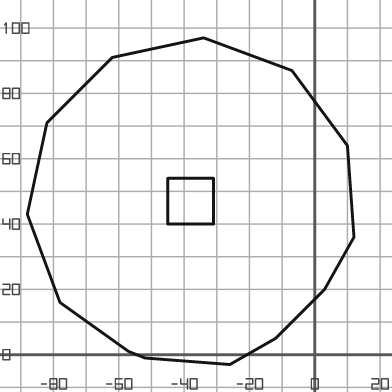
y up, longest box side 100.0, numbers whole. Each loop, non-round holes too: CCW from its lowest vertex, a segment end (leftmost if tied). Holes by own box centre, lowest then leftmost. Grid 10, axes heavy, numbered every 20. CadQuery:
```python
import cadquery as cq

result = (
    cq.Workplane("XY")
    .moveTo(-26.0, -3.0)
    .lineTo(-12.0, 5.0)
    .lineTo(3.0, 20.0)
    .lineTo(12.0, 36.0)
    .lineTo(10.0, 64.0)
    .lineTo(-7.0, 87.0)
    .lineTo(-34.0, 97.0)
    .lineTo(-62.0, 91.0)
    .lineTo(-82.0, 71.0)
    .lineTo(-88.0, 43.0)
    .lineTo(-78.0, 16.0)
    .lineTo(-57.0, 1.0)
    .lineTo(-52.0, -1.0)
    .close()
    .moveTo(-45.0, 40.0)
    .lineTo(-31.0, 40.0)
    .lineTo(-31.0, 54.0)
    .lineTo(-45.0, 54.0)
    .close()
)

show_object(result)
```